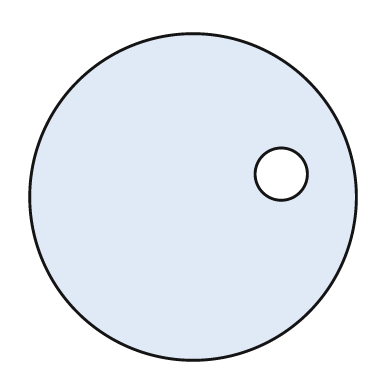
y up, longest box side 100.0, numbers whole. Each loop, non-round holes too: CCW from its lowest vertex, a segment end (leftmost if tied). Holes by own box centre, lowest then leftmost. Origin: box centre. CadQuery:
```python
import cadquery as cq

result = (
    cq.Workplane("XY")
    .moveTo(0.0, 0.0)
    .circle(50.0)
    .moveTo(27.0, 7.0)
    .circle(8.0)
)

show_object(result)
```